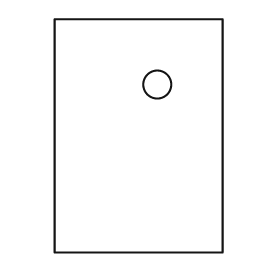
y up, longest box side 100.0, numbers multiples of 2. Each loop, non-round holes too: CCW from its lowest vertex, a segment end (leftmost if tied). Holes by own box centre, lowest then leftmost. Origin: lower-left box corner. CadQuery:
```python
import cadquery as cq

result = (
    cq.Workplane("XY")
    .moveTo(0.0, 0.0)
    .lineTo(72.0, 0.0)
    .lineTo(72.0, 100.0)
    .lineTo(0.0, 100.0)
    .close()
    .moveTo(44.0, 72.0)
    .circle(6.0)
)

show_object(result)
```